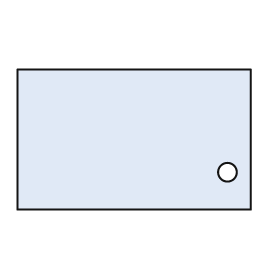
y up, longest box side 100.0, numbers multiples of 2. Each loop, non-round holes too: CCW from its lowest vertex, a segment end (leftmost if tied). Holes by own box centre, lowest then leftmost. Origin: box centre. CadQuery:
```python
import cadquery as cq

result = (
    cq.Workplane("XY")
    .moveTo(-50.0, -30.0)
    .lineTo(50.0, -30.0)
    .lineTo(50.0, 30.0)
    .lineTo(-50.0, 30.0)
    .close()
    .moveTo(40.0, -14.0)
    .circle(4.0)
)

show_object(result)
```